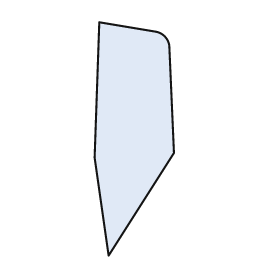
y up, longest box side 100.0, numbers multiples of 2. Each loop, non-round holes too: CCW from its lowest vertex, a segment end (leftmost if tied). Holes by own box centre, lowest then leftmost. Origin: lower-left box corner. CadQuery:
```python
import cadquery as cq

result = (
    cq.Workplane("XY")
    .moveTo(6.0, 0.0)
    .lineTo(34.0, 44.0)
    .lineTo(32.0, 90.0)
    .threePointArc((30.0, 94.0), (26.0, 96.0))
    .lineTo(2.0, 100.0)
    .lineTo(0.0, 42.0)
    .close()
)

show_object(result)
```